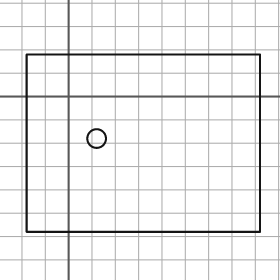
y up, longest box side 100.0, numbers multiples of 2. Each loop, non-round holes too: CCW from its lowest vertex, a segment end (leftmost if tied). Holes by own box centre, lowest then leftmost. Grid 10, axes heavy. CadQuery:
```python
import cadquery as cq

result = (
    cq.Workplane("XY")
    .moveTo(-18.0, -58.0)
    .lineTo(82.0, -58.0)
    .lineTo(82.0, 18.0)
    .lineTo(-18.0, 18.0)
    .close()
    .moveTo(12.0, -18.0)
    .circle(4.0)
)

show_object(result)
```